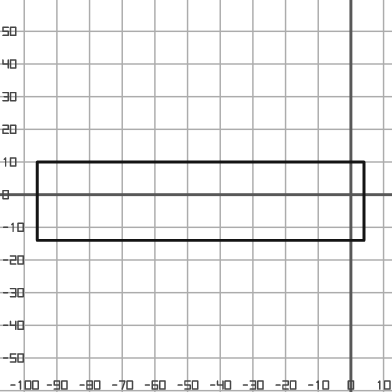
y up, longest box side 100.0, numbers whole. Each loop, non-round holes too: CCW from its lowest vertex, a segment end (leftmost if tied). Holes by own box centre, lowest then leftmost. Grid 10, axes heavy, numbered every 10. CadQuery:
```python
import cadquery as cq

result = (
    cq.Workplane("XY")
    .moveTo(-96.0, -14.0)
    .lineTo(4.0, -14.0)
    .lineTo(4.0, 10.0)
    .lineTo(-96.0, 10.0)
    .close()
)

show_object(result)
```